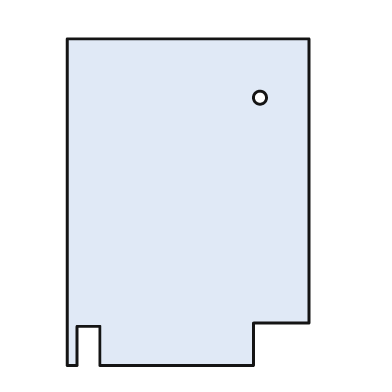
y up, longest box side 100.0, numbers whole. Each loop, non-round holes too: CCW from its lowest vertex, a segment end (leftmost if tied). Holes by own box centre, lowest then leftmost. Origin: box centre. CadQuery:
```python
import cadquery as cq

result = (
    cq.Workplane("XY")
    .moveTo(-37.0, -50.0)
    .lineTo(-34.0, -50.0)
    .lineTo(-34.0, -38.0)
    .lineTo(-27.0, -38.0)
    .lineTo(-27.0, -50.0)
    .lineTo(20.0, -50.0)
    .lineTo(20.0, -37.0)
    .lineTo(37.0, -37.0)
    .lineTo(37.0, 50.0)
    .lineTo(-37.0, 50.0)
    .close()
    .moveTo(22.0, 32.0)
    .circle(2.0)
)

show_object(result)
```